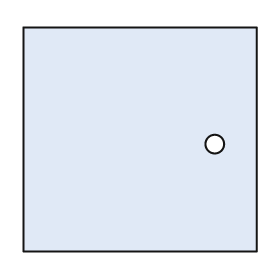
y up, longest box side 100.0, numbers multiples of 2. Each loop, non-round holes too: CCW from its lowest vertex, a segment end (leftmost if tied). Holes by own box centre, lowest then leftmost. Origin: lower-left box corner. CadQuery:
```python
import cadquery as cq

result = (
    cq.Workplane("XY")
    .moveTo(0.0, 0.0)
    .lineTo(100.0, 0.0)
    .lineTo(100.0, 96.0)
    .lineTo(0.0, 96.0)
    .close()
    .moveTo(82.0, 46.0)
    .circle(4.0)
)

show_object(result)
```